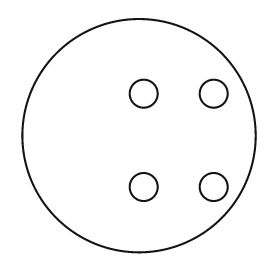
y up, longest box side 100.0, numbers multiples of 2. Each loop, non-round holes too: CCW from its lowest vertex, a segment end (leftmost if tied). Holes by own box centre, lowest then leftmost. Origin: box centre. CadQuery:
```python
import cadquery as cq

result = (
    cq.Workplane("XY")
    .moveTo(0.0, 0.0)
    .circle(50.0)
    .moveTo(2.0, -22.0)
    .circle(6.0)
    .moveTo(32.0, -22.0)
    .circle(6.0)
    .moveTo(2.0, 18.0)
    .circle(6.0)
    .moveTo(32.0, 18.0)
    .circle(6.0)
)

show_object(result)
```